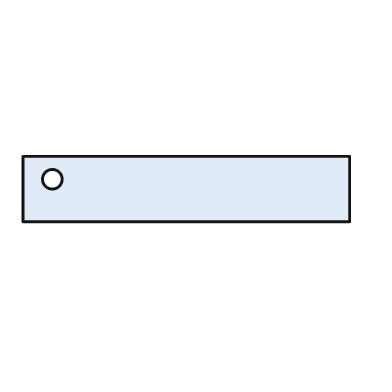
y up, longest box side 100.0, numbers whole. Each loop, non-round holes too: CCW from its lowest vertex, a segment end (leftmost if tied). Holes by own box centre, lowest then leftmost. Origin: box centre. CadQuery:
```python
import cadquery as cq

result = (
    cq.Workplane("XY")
    .moveTo(-50.0, -10.0)
    .lineTo(50.0, -10.0)
    .lineTo(50.0, 10.0)
    .lineTo(-50.0, 10.0)
    .close()
    .moveTo(-41.0, 3.0)
    .circle(3.0)
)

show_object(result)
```